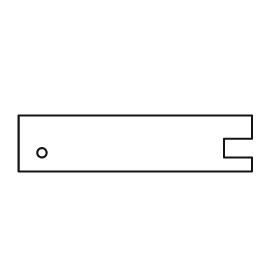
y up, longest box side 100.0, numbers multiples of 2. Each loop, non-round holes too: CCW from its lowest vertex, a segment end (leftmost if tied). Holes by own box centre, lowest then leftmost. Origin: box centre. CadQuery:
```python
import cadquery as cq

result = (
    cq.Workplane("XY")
    .moveTo(-50.0, -12.0)
    .lineTo(50.0, -12.0)
    .lineTo(50.0, -6.0)
    .lineTo(38.0, -6.0)
    .lineTo(38.0, 2.0)
    .lineTo(50.0, 2.0)
    .lineTo(50.0, 12.0)
    .lineTo(-50.0, 12.0)
    .close()
    .moveTo(-40.0, -4.0)
    .circle(2.0)
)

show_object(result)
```